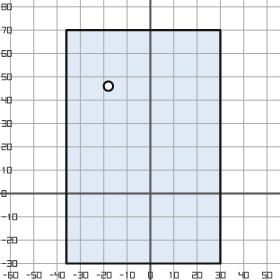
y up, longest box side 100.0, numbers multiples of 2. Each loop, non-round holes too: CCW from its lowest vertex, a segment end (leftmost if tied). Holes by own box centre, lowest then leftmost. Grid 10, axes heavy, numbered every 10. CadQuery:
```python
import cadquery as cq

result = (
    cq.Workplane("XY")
    .moveTo(-36.0, -30.0)
    .lineTo(30.0, -30.0)
    .lineTo(30.0, 70.0)
    .lineTo(-36.0, 70.0)
    .close()
    .moveTo(-18.0, 46.0)
    .circle(2.0)
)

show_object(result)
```